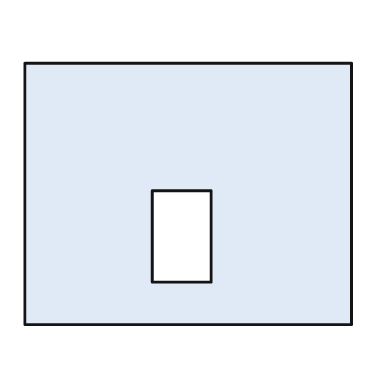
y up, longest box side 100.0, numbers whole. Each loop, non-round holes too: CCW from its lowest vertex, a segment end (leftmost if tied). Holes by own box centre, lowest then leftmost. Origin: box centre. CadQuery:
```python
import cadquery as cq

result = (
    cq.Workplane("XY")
    .moveTo(-50.0, -40.0)
    .lineTo(50.0, -40.0)
    .lineTo(50.0, 40.0)
    .lineTo(-50.0, 40.0)
    .close()
    .moveTo(-11.0, -27.0)
    .lineTo(7.0, -27.0)
    .lineTo(7.0, 1.0)
    .lineTo(-11.0, 1.0)
    .close()
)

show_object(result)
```